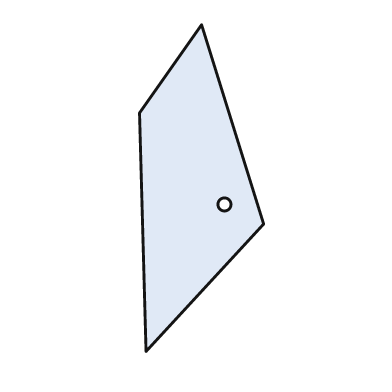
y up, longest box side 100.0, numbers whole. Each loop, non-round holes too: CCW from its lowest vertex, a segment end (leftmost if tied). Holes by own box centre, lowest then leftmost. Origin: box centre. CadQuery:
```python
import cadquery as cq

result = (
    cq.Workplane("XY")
    .moveTo(-17.0, -50.0)
    .lineTo(19.0, -11.0)
    .lineTo(0.0, 50.0)
    .lineTo(-19.0, 23.0)
    .close()
    .moveTo(7.0, -5.0)
    .circle(2.0)
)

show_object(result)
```